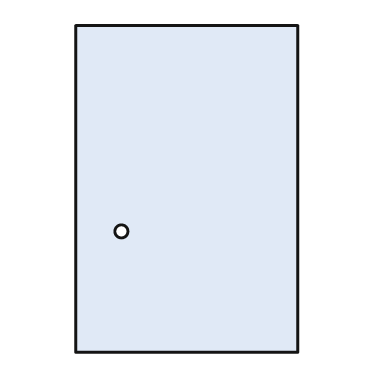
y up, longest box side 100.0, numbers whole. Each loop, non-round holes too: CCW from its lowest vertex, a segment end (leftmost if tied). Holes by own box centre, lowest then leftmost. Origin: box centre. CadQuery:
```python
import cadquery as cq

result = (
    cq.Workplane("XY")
    .moveTo(-34.0, -50.0)
    .lineTo(34.0, -50.0)
    .lineTo(34.0, 50.0)
    .lineTo(-34.0, 50.0)
    .close()
    .moveTo(-20.0, -13.0)
    .circle(2.0)
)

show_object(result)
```